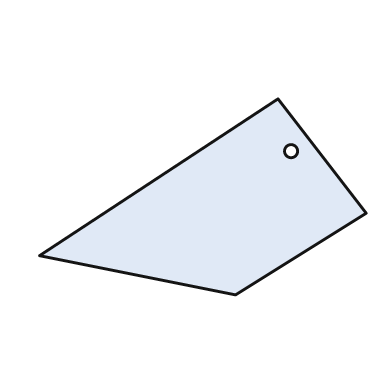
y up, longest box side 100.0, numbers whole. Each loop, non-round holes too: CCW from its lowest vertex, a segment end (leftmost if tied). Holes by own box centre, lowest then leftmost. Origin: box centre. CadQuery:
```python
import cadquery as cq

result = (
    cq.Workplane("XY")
    .moveTo(10.0, -30.0)
    .lineTo(50.0, -5.0)
    .lineTo(23.0, 30.0)
    .lineTo(-50.0, -18.0)
    .close()
    .moveTo(27.0, 14.0)
    .circle(2.0)
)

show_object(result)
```